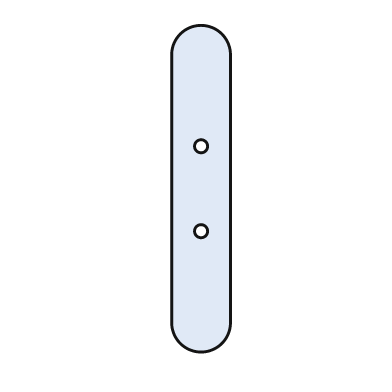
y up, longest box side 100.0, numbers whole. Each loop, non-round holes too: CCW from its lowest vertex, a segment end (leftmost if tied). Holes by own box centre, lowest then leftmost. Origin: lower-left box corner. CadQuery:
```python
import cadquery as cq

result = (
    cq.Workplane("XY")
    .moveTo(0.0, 9.0)
    .threePointArc((9.0, 0.0), (18.0, 9.0))
    .lineTo(18.0, 91.0)
    .threePointArc((9.0, 100.0), (0.0, 91.0))
    .close()
    .moveTo(9.0, 37.0)
    .circle(2.0)
    .moveTo(9.0, 63.0)
    .circle(2.0)
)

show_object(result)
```